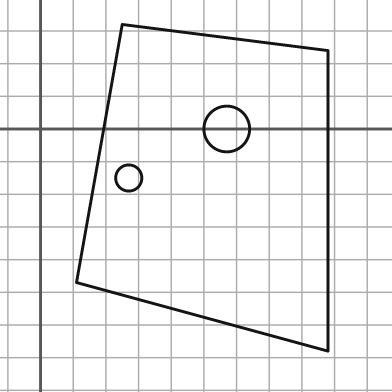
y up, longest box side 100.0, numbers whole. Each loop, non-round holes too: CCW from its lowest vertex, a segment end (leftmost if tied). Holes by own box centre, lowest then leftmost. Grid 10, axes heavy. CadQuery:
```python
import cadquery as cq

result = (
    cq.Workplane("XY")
    .moveTo(88.0, -68.0)
    .lineTo(88.0, 24.0)
    .lineTo(25.0, 32.0)
    .lineTo(11.0, -47.0)
    .close()
    .moveTo(27.0, -15.0)
    .circle(4.0)
    .moveTo(57.0, 0.0)
    .circle(7.0)
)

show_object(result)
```